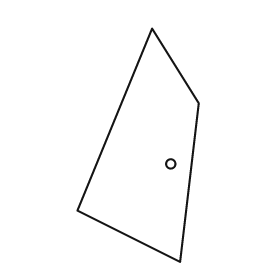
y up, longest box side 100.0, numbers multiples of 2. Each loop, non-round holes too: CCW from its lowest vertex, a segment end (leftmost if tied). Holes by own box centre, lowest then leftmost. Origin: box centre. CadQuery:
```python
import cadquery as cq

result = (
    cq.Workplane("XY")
    .moveTo(18.0, -50.0)
    .lineTo(26.0, 18.0)
    .lineTo(6.0, 50.0)
    .lineTo(-26.0, -28.0)
    .close()
    .moveTo(14.0, -8.0)
    .circle(2.0)
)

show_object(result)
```